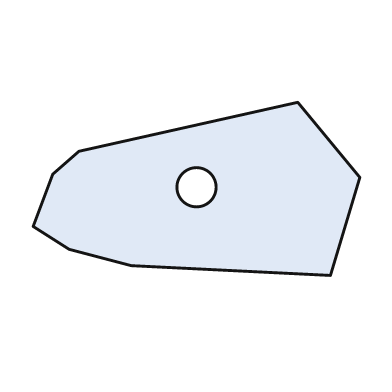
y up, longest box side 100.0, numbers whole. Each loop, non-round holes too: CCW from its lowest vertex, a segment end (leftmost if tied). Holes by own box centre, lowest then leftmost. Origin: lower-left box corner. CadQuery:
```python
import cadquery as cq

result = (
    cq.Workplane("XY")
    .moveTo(91.0, 0.0)
    .lineTo(100.0, 30.0)
    .lineTo(81.0, 53.0)
    .lineTo(14.0, 38.0)
    .lineTo(6.0, 31.0)
    .lineTo(0.0, 15.0)
    .lineTo(11.0, 8.0)
    .lineTo(30.0, 3.0)
    .close()
    .moveTo(50.0, 27.0)
    .circle(6.0)
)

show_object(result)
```